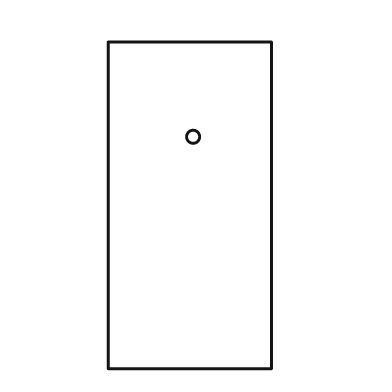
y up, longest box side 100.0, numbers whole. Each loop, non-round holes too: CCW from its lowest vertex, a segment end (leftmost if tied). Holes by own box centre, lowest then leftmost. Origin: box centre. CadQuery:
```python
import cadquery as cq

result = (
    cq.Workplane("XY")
    .moveTo(-25.0, -50.0)
    .lineTo(25.0, -50.0)
    .lineTo(25.0, 50.0)
    .lineTo(-25.0, 50.0)
    .close()
    .moveTo(1.0, 21.0)
    .circle(2.0)
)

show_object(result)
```